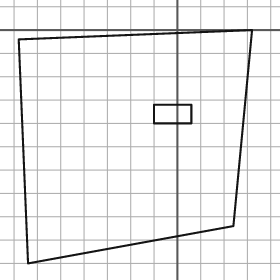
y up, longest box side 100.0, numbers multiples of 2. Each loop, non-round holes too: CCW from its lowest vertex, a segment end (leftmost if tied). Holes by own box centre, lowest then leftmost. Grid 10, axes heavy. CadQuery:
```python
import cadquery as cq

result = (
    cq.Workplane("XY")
    .moveTo(-64.0, -100.0)
    .lineTo(24.0, -84.0)
    .lineTo(32.0, 0.0)
    .lineTo(-68.0, -4.0)
    .close()
    .moveTo(-10.0, -40.0)
    .lineTo(6.0, -40.0)
    .lineTo(6.0, -32.0)
    .lineTo(-10.0, -32.0)
    .close()
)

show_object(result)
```